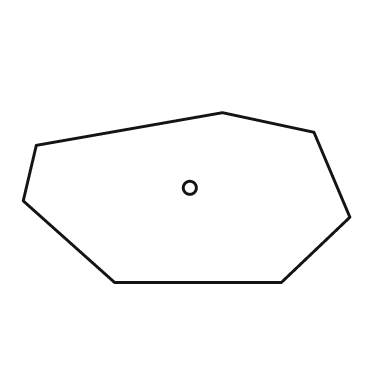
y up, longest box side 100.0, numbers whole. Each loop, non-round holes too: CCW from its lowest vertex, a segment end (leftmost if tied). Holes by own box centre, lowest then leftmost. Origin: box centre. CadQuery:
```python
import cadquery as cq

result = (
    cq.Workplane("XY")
    .moveTo(-22.0, -26.0)
    .lineTo(29.0, -26.0)
    .lineTo(50.0, -6.0)
    .lineTo(39.0, 20.0)
    .lineTo(11.0, 26.0)
    .lineTo(-46.0, 16.0)
    .lineTo(-50.0, -1.0)
    .close()
    .moveTo(1.0, 3.0)
    .circle(2.0)
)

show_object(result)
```